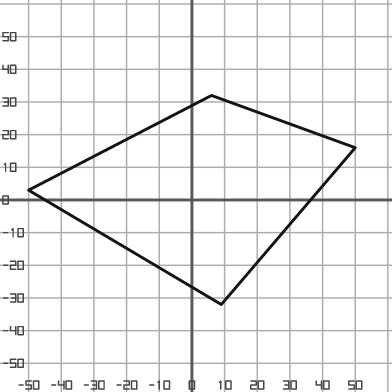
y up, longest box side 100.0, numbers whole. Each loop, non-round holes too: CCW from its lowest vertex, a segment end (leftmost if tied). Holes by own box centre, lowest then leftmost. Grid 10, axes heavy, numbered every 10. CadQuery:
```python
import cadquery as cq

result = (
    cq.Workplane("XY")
    .moveTo(9.0, -32.0)
    .lineTo(50.0, 16.0)
    .lineTo(6.0, 32.0)
    .lineTo(-50.0, 3.0)
    .close()
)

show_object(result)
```